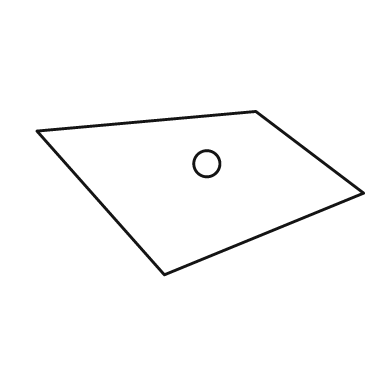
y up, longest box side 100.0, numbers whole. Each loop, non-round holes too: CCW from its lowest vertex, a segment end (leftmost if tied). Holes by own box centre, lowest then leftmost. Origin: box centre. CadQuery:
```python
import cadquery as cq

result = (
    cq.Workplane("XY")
    .moveTo(-11.0, -25.0)
    .lineTo(50.0, 0.0)
    .lineTo(17.0, 25.0)
    .lineTo(-50.0, 19.0)
    .close()
    .moveTo(2.0, 9.0)
    .circle(4.0)
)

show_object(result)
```